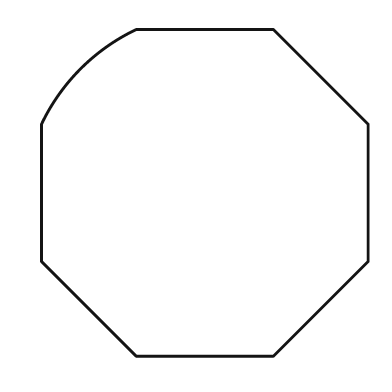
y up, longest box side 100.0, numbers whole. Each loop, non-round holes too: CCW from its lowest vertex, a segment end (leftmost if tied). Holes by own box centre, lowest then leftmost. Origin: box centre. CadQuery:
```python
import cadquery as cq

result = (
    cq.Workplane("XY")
    .moveTo(-21.0, -50.0)
    .lineTo(21.0, -50.0)
    .lineTo(50.0, -21.0)
    .lineTo(50.0, 21.0)
    .lineTo(21.0, 50.0)
    .lineTo(-21.0, 50.0)
    .threePointArc((-38.0, 38.0), (-50.0, 21.0))
    .lineTo(-50.0, -21.0)
    .close()
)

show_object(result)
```